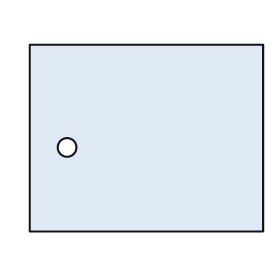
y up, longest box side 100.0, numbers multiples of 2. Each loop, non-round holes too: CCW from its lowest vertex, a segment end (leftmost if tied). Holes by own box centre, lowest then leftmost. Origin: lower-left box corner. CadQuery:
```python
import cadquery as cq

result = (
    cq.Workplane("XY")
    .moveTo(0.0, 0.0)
    .lineTo(100.0, 0.0)
    .lineTo(100.0, 80.0)
    .lineTo(0.0, 80.0)
    .close()
    .moveTo(16.0, 36.0)
    .circle(4.0)
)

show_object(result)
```